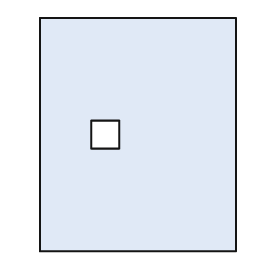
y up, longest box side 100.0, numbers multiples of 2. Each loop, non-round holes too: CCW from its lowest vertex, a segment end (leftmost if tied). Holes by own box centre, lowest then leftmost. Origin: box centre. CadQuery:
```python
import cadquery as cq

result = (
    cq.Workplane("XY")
    .moveTo(-42.0, -50.0)
    .lineTo(42.0, -50.0)
    .lineTo(42.0, 50.0)
    .lineTo(-42.0, 50.0)
    .close()
    .moveTo(-20.0, -6.0)
    .lineTo(-8.0, -6.0)
    .lineTo(-8.0, 6.0)
    .lineTo(-20.0, 6.0)
    .close()
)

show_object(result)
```